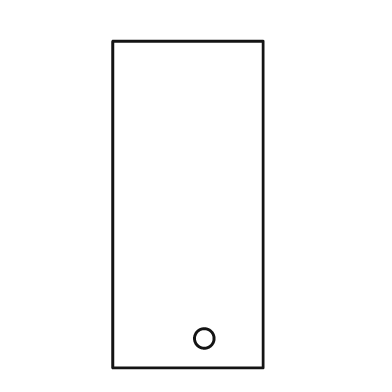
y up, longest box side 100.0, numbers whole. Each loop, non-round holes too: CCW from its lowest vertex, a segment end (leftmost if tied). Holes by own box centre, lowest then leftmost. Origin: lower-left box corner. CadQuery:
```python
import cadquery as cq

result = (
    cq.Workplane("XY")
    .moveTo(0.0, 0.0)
    .lineTo(46.0, 0.0)
    .lineTo(46.0, 100.0)
    .lineTo(0.0, 100.0)
    .close()
    .moveTo(28.0, 9.0)
    .circle(3.0)
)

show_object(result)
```